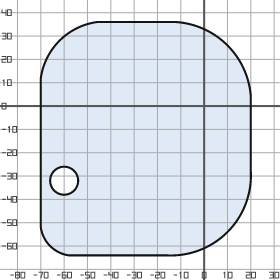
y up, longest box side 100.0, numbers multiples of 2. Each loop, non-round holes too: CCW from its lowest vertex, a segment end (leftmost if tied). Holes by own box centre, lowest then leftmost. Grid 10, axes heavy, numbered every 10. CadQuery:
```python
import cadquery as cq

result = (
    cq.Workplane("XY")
    .moveTo(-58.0, -64.0)
    .lineTo(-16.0, -64.0)
    .threePointArc((10.0, -54.0), (20.0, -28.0))
    .lineTo(20.0, 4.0)
    .threePointArc((10.0, 26.0), (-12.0, 36.0))
    .lineTo(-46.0, 36.0)
    .threePointArc((-62.0, 28.0), (-70.0, 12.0))
    .lineTo(-70.0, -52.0)
    .threePointArc((-66.0, -60.0), (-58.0, -64.0))
    .close()
    .moveTo(-60.0, -32.0)
    .circle(6.0)
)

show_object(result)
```